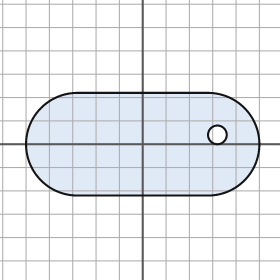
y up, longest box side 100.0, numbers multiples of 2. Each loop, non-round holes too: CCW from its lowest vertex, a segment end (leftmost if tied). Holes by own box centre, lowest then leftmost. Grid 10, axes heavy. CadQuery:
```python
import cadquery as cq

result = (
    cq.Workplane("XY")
    .moveTo(-28.0, -22.0)
    .lineTo(28.0, -22.0)
    .threePointArc((50.0, 0.0), (28.0, 22.0))
    .lineTo(-28.0, 22.0)
    .threePointArc((-50.0, 0.0), (-28.0, -22.0))
    .close()
    .moveTo(32.0, 4.0)
    .circle(4.0)
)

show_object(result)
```